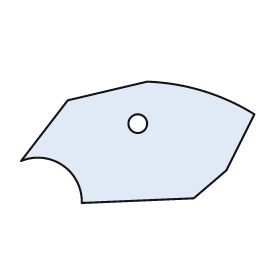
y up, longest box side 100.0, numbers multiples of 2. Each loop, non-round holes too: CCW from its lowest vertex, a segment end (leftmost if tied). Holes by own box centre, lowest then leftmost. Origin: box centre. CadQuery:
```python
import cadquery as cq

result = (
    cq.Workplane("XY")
    .moveTo(-24.0, -26.0)
    .lineTo(24.0, -24.0)
    .lineTo(38.0, -12.0)
    .lineTo(50.0, 12.0)
    .threePointArc((28.0, 22.0), (4.0, 26.0))
    .lineTo(-30.0, 18.0)
    .lineTo(-50.0, -8.0)
    .threePointArc((-32.0, -10.0), (-24.0, -26.0))
    .close()
    .moveTo(0.0, 8.0)
    .circle(4.0)
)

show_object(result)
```